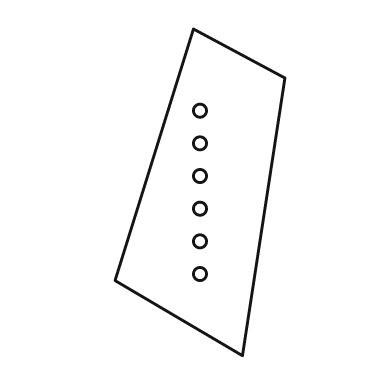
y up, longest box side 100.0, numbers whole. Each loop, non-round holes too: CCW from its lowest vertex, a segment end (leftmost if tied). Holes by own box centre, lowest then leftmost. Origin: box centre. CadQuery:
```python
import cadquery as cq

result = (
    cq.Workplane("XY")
    .moveTo(13.0, -50.0)
    .lineTo(26.0, 35.0)
    .lineTo(-2.0, 50.0)
    .lineTo(-26.0, -27.0)
    .close()
    .moveTo(0.0, -25.0)
    .circle(2.0)
    .moveTo(0.0, -15.0)
    .circle(2.0)
    .moveTo(0.0, -5.0)
    .circle(2.0)
    .moveTo(0.0, 5.0)
    .circle(2.0)
    .moveTo(0.0, 15.0)
    .circle(2.0)
    .moveTo(0.0, 25.0)
    .circle(2.0)
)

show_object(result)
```